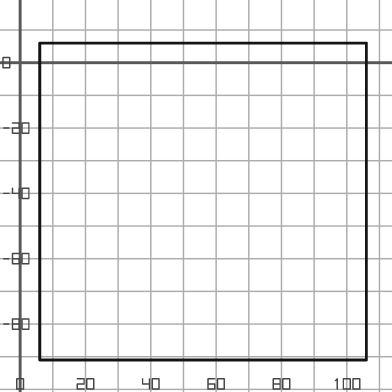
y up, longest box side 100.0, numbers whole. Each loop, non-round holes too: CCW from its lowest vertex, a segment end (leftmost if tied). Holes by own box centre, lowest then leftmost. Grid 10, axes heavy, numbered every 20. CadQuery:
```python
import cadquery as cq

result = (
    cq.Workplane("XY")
    .moveTo(6.0, -91.0)
    .lineTo(106.0, -91.0)
    .lineTo(106.0, 6.0)
    .lineTo(6.0, 6.0)
    .close()
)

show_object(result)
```